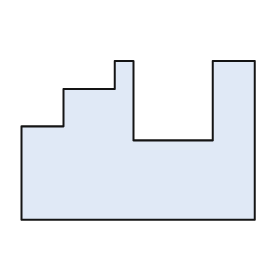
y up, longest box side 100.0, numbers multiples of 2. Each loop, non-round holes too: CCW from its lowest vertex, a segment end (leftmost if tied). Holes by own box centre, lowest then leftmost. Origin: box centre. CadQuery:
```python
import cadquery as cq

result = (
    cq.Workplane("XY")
    .moveTo(-50.0, -34.0)
    .lineTo(50.0, -34.0)
    .lineTo(50.0, 34.0)
    .lineTo(32.0, 34.0)
    .lineTo(32.0, 0.0)
    .lineTo(-2.0, 0.0)
    .lineTo(-2.0, 34.0)
    .lineTo(-10.0, 34.0)
    .lineTo(-10.0, 22.0)
    .lineTo(-32.0, 22.0)
    .lineTo(-32.0, 6.0)
    .lineTo(-50.0, 6.0)
    .close()
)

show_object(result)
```